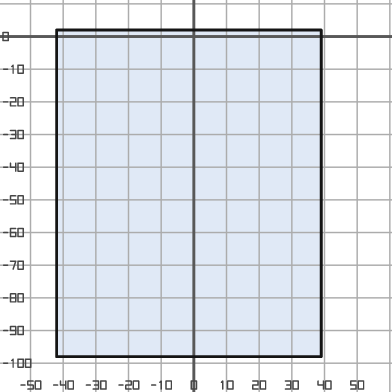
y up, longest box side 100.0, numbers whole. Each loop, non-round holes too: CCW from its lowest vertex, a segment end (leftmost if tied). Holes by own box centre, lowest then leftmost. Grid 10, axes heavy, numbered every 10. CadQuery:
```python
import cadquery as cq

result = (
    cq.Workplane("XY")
    .moveTo(-42.0, -98.0)
    .lineTo(39.0, -98.0)
    .lineTo(39.0, 2.0)
    .lineTo(-42.0, 2.0)
    .close()
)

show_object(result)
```